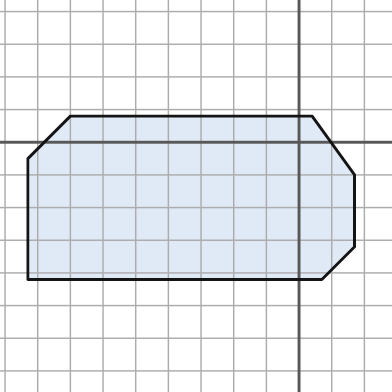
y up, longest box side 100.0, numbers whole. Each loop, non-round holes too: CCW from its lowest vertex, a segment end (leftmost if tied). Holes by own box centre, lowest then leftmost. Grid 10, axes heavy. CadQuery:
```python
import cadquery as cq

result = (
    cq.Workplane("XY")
    .moveTo(-83.0, -42.0)
    .lineTo(7.0, -42.0)
    .lineTo(17.0, -32.0)
    .lineTo(17.0, -10.0)
    .lineTo(4.0, 8.0)
    .lineTo(-70.0, 8.0)
    .lineTo(-83.0, -5.0)
    .close()
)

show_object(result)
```